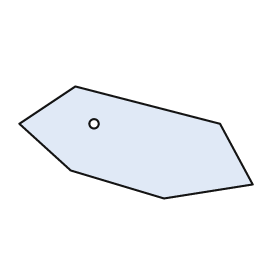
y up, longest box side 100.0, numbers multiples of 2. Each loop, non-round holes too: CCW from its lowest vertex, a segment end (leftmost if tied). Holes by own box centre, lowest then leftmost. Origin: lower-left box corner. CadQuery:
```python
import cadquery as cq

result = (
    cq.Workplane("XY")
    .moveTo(62.0, 0.0)
    .lineTo(100.0, 6.0)
    .lineTo(86.0, 32.0)
    .lineTo(24.0, 48.0)
    .lineTo(0.0, 32.0)
    .lineTo(22.0, 12.0)
    .close()
    .moveTo(32.0, 32.0)
    .circle(2.0)
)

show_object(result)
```